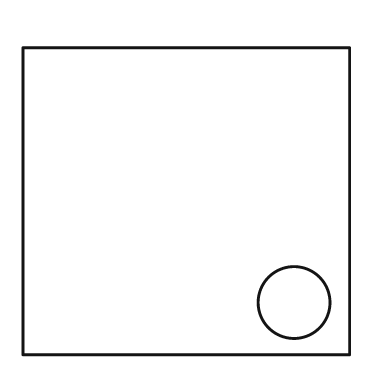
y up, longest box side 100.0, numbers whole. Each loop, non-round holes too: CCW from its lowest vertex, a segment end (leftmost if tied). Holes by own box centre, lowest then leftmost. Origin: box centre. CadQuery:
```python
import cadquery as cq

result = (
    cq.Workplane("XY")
    .moveTo(-50.0, -47.0)
    .lineTo(50.0, -47.0)
    .lineTo(50.0, 47.0)
    .lineTo(-50.0, 47.0)
    .close()
    .moveTo(33.0, -31.0)
    .circle(11.0)
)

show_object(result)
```